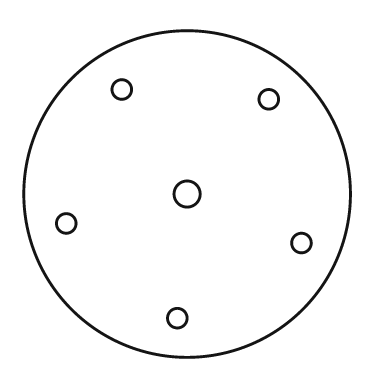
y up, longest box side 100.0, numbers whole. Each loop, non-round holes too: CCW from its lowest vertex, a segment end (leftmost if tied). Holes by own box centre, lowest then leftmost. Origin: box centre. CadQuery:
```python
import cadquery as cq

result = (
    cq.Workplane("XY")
    .moveTo(0.0, 0.0)
    .circle(50.0)
    .moveTo(-3.0, -38.0)
    .circle(3.0)
    .moveTo(35.0, -15.0)
    .circle(3.0)
    .moveTo(-37.0, -9.0)
    .circle(3.0)
    .moveTo(0.0, 0.0)
    .circle(4.0)
    .moveTo(25.0, 29.0)
    .circle(3.0)
    .moveTo(-20.0, 32.0)
    .circle(3.0)
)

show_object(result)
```